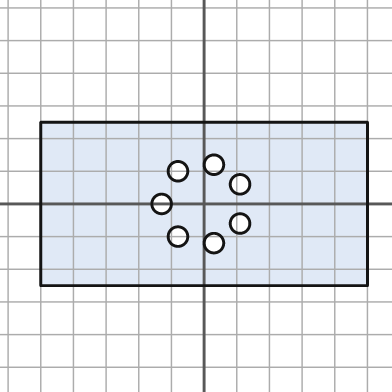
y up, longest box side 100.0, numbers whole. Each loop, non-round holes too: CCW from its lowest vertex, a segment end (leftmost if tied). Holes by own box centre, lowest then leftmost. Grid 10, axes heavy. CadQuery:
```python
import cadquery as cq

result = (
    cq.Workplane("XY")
    .moveTo(-50.0, -25.0)
    .lineTo(50.0, -25.0)
    .lineTo(50.0, 25.0)
    .lineTo(-50.0, 25.0)
    .close()
    .moveTo(3.0, -12.0)
    .circle(3.0)
    .moveTo(-8.0, -10.0)
    .circle(3.0)
    .moveTo(11.0, -6.0)
    .circle(3.0)
    .moveTo(-13.0, 0.0)
    .circle(3.0)
    .moveTo(11.0, 6.0)
    .circle(3.0)
    .moveTo(-8.0, 10.0)
    .circle(3.0)
    .moveTo(3.0, 12.0)
    .circle(3.0)
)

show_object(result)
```